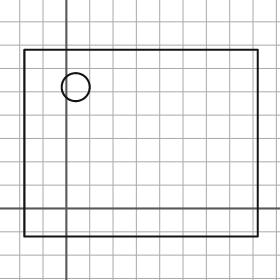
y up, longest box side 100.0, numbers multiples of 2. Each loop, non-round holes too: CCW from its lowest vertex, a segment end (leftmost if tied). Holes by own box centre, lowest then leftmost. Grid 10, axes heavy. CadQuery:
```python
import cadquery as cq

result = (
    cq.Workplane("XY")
    .moveTo(-18.0, -12.0)
    .lineTo(82.0, -12.0)
    .lineTo(82.0, 68.0)
    .lineTo(-18.0, 68.0)
    .close()
    .moveTo(4.0, 52.0)
    .circle(6.0)
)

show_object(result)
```